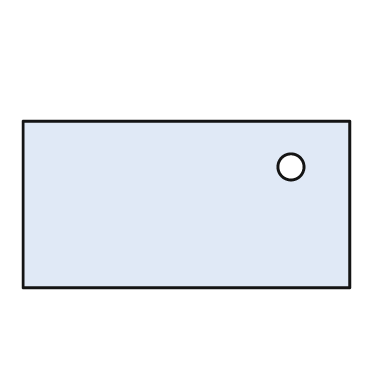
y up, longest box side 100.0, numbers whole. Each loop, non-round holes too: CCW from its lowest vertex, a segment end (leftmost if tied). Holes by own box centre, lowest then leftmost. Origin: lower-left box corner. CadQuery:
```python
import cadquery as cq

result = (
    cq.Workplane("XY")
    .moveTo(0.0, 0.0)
    .lineTo(100.0, 0.0)
    .lineTo(100.0, 51.0)
    .lineTo(0.0, 51.0)
    .close()
    .moveTo(82.0, 37.0)
    .circle(4.0)
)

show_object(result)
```